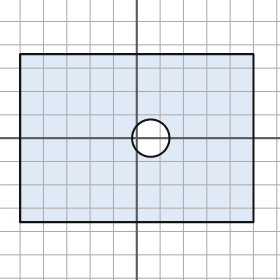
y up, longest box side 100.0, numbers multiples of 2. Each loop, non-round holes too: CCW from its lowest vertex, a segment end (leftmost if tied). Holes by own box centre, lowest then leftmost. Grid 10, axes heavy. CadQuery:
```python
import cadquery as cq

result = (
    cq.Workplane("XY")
    .moveTo(-50.0, -36.0)
    .lineTo(50.0, -36.0)
    .lineTo(50.0, 36.0)
    .lineTo(-50.0, 36.0)
    .close()
    .moveTo(6.0, 0.0)
    .circle(8.0)
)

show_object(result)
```